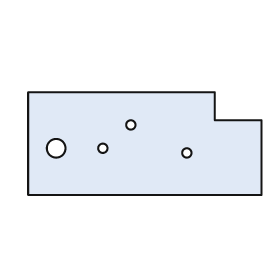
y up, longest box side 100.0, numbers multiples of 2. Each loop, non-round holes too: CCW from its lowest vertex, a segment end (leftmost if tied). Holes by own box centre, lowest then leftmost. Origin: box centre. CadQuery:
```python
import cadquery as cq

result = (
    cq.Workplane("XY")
    .moveTo(-50.0, -22.0)
    .lineTo(50.0, -22.0)
    .lineTo(50.0, 10.0)
    .lineTo(30.0, 10.0)
    .lineTo(30.0, 22.0)
    .lineTo(-50.0, 22.0)
    .close()
    .moveTo(18.0, -4.0)
    .circle(2.0)
    .moveTo(-38.0, -2.0)
    .circle(4.0)
    .moveTo(-18.0, -2.0)
    .circle(2.0)
    .moveTo(-6.0, 8.0)
    .circle(2.0)
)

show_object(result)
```